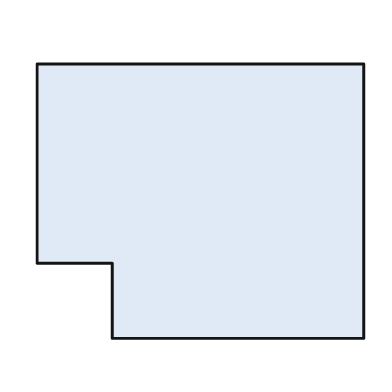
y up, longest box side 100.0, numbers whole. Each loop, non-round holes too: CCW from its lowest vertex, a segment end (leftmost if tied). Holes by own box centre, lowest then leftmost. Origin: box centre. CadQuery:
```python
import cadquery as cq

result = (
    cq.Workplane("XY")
    .moveTo(-27.0, -42.0)
    .lineTo(50.0, -42.0)
    .lineTo(50.0, 42.0)
    .lineTo(-50.0, 42.0)
    .lineTo(-50.0, -19.0)
    .lineTo(-27.0, -19.0)
    .close()
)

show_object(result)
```